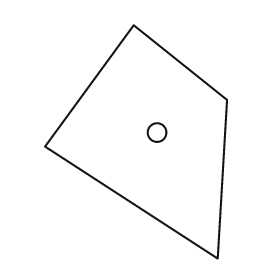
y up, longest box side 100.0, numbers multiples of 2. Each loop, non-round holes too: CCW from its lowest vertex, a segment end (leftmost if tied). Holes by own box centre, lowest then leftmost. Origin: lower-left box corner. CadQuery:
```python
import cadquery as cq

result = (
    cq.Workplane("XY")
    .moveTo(74.0, 0.0)
    .lineTo(78.0, 68.0)
    .lineTo(38.0, 100.0)
    .lineTo(0.0, 48.0)
    .close()
    .moveTo(48.0, 54.0)
    .circle(4.0)
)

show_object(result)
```